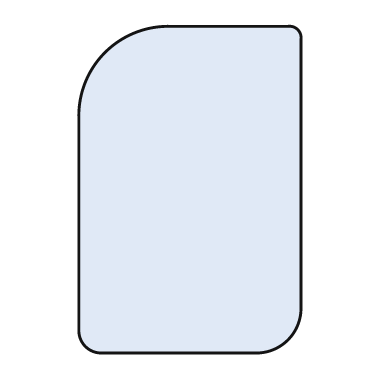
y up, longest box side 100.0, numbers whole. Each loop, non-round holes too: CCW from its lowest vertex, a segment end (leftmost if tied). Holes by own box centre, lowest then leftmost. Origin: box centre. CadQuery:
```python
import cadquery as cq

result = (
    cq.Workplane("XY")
    .moveTo(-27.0, -50.0)
    .lineTo(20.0, -50.0)
    .threePointArc((30.0, -46.0), (34.0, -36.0))
    .lineTo(34.0, 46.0)
    .threePointArc((33.0, 49.0), (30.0, 50.0))
    .lineTo(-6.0, 50.0)
    .threePointArc((-26.0, 42.0), (-34.0, 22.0))
    .lineTo(-34.0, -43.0)
    .threePointArc((-32.0, -48.0), (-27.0, -50.0))
    .close()
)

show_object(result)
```